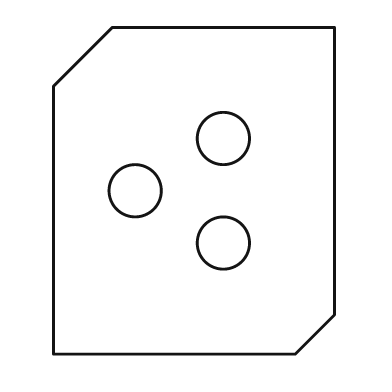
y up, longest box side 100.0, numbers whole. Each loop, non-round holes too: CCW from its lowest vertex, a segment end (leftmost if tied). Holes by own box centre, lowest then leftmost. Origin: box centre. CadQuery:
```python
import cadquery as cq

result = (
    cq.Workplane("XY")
    .moveTo(-43.0, -50.0)
    .lineTo(31.0, -50.0)
    .lineTo(43.0, -38.0)
    .lineTo(43.0, 50.0)
    .lineTo(-25.0, 50.0)
    .lineTo(-43.0, 32.0)
    .close()
    .moveTo(9.0, -16.0)
    .circle(8.0)
    .moveTo(-18.0, 0.0)
    .circle(8.0)
    .moveTo(9.0, 16.0)
    .circle(8.0)
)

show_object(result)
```